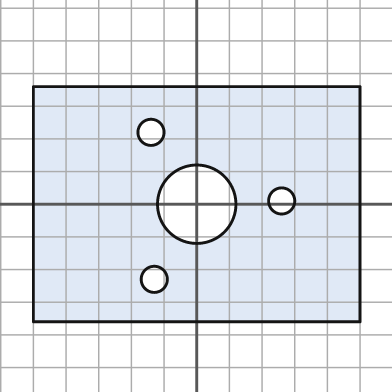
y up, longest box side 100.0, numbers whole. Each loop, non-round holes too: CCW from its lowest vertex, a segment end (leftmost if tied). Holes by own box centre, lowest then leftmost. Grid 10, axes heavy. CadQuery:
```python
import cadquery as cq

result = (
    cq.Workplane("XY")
    .moveTo(-50.0, -36.0)
    .lineTo(50.0, -36.0)
    .lineTo(50.0, 36.0)
    .lineTo(-50.0, 36.0)
    .close()
    .moveTo(-13.0, -23.0)
    .circle(4.0)
    .moveTo(0.0, 0.0)
    .circle(12.0)
    .moveTo(26.0, 1.0)
    .circle(4.0)
    .moveTo(-14.0, 22.0)
    .circle(4.0)
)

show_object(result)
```